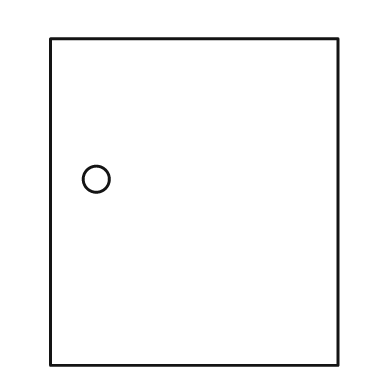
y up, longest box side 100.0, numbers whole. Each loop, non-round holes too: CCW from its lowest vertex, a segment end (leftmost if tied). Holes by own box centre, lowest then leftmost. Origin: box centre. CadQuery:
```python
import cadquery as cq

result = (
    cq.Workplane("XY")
    .moveTo(-44.0, -50.0)
    .lineTo(44.0, -50.0)
    .lineTo(44.0, 50.0)
    .lineTo(-44.0, 50.0)
    .close()
    .moveTo(-30.0, 7.0)
    .circle(4.0)
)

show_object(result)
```